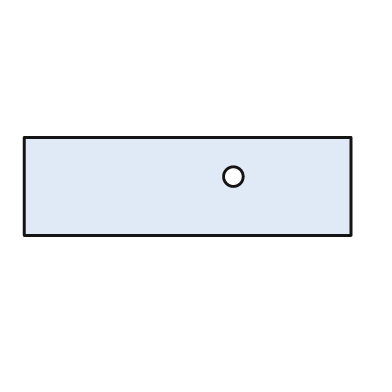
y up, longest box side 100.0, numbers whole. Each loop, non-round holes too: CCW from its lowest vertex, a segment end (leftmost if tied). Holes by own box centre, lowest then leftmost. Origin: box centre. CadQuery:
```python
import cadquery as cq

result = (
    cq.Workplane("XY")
    .moveTo(-50.0, -15.0)
    .lineTo(50.0, -15.0)
    .lineTo(50.0, 15.0)
    .lineTo(-50.0, 15.0)
    .close()
    .moveTo(14.0, 3.0)
    .circle(3.0)
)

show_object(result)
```